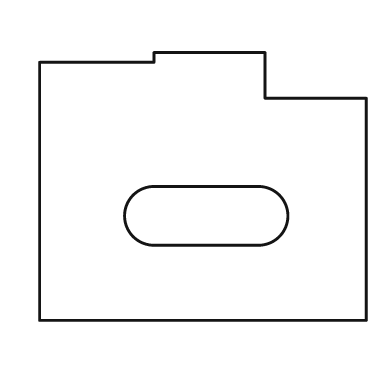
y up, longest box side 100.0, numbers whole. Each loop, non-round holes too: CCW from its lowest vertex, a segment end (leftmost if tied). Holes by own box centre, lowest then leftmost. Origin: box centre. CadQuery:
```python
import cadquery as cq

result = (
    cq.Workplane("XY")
    .moveTo(-50.0, -41.0)
    .lineTo(50.0, -41.0)
    .lineTo(50.0, 27.0)
    .lineTo(19.0, 27.0)
    .lineTo(19.0, 41.0)
    .lineTo(-15.0, 41.0)
    .lineTo(-15.0, 38.0)
    .lineTo(-50.0, 38.0)
    .close()
    .moveTo(-15.0, -18.0)
    .lineTo(17.0, -18.0)
    .threePointArc((26.0, -9.0), (17.0, 0.0))
    .lineTo(-15.0, 0.0)
    .threePointArc((-24.0, -9.0), (-15.0, -18.0))
    .close()
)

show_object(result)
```